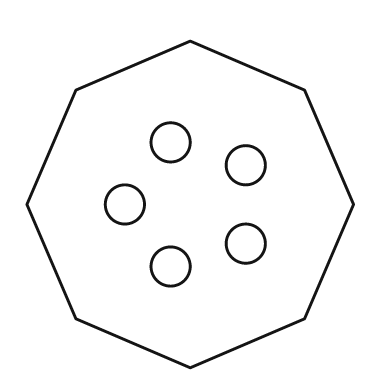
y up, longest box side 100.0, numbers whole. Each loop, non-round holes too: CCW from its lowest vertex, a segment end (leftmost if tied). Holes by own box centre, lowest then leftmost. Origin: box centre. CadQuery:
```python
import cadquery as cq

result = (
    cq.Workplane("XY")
    .moveTo(0.0, -50.0)
    .lineTo(35.0, -35.0)
    .lineTo(50.0, 0.0)
    .lineTo(35.0, 35.0)
    .lineTo(0.0, 50.0)
    .lineTo(-35.0, 35.0)
    .lineTo(-50.0, 0.0)
    .lineTo(-35.0, -35.0)
    .close()
    .moveTo(-6.0, -19.0)
    .circle(6.0)
    .moveTo(17.0, -12.0)
    .circle(6.0)
    .moveTo(-20.0, 0.0)
    .circle(6.0)
    .moveTo(17.0, 12.0)
    .circle(6.0)
    .moveTo(-6.0, 19.0)
    .circle(6.0)
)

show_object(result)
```